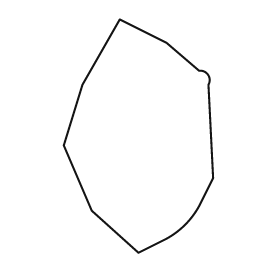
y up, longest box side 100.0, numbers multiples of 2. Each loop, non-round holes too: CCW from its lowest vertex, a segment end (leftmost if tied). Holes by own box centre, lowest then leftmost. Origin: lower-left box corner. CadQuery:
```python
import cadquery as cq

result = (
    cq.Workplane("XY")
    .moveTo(32.0, 0.0)
    .lineTo(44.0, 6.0)
    .threePointArc((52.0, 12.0), (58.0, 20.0))
    .lineTo(64.0, 32.0)
    .lineTo(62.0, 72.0)
    .threePointArc((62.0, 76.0), (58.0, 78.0))
    .lineTo(44.0, 90.0)
    .lineTo(24.0, 100.0)
    .lineTo(8.0, 72.0)
    .lineTo(0.0, 46.0)
    .lineTo(12.0, 18.0)
    .close()
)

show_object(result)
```